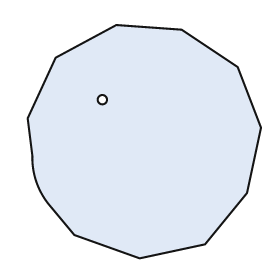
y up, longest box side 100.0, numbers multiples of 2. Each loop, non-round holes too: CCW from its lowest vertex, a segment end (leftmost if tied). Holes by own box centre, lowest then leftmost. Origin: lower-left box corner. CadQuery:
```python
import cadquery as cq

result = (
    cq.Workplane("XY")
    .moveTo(48.0, 0.0)
    .lineTo(76.0, 6.0)
    .lineTo(94.0, 28.0)
    .lineTo(100.0, 56.0)
    .lineTo(90.0, 82.0)
    .lineTo(66.0, 98.0)
    .lineTo(38.0, 100.0)
    .lineTo(12.0, 86.0)
    .lineTo(0.0, 60.0)
    .lineTo(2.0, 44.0)
    .threePointArc((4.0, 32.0), (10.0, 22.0))
    .lineTo(20.0, 10.0)
    .close()
    .moveTo(32.0, 68.0)
    .circle(2.0)
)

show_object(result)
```